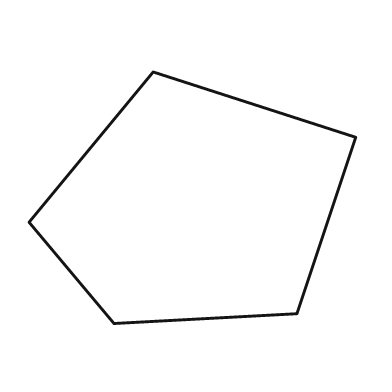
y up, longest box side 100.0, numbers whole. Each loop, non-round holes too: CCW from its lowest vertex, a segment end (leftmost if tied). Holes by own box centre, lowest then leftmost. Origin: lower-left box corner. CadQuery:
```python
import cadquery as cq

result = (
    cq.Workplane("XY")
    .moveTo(26.0, 0.0)
    .lineTo(82.0, 3.0)
    .lineTo(100.0, 57.0)
    .lineTo(38.0, 77.0)
    .lineTo(0.0, 31.0)
    .close()
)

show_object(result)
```